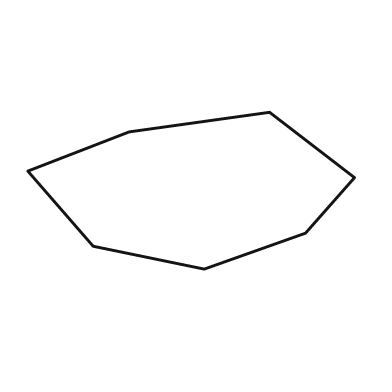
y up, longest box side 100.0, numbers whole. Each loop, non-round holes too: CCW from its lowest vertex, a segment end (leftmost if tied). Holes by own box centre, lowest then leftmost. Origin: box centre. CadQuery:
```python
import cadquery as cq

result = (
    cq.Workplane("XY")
    .moveTo(4.0, -24.0)
    .lineTo(35.0, -13.0)
    .lineTo(50.0, 4.0)
    .lineTo(24.0, 24.0)
    .lineTo(-19.0, 18.0)
    .lineTo(-50.0, 6.0)
    .lineTo(-30.0, -17.0)
    .close()
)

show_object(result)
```